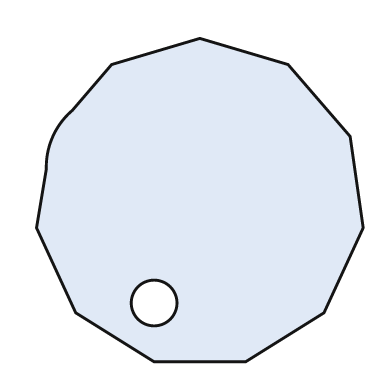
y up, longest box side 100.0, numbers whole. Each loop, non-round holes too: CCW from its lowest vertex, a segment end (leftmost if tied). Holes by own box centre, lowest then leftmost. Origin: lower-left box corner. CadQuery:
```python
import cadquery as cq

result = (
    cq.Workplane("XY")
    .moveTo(36.0, 0.0)
    .lineTo(64.0, 0.0)
    .lineTo(88.0, 15.0)
    .lineTo(100.0, 41.0)
    .lineTo(96.0, 69.0)
    .lineTo(77.0, 91.0)
    .lineTo(50.0, 99.0)
    .lineTo(23.0, 91.0)
    .lineTo(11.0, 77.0)
    .threePointArc((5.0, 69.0), (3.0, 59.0))
    .lineTo(0.0, 41.0)
    .lineTo(12.0, 15.0)
    .close()
    .moveTo(36.0, 18.0)
    .circle(7.0)
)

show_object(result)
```